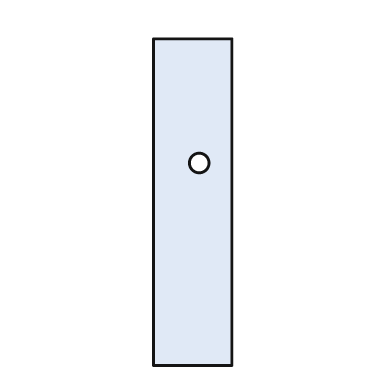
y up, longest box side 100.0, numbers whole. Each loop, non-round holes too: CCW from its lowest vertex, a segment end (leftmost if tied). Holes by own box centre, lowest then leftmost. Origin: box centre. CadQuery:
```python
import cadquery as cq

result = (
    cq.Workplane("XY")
    .moveTo(-12.0, -50.0)
    .lineTo(12.0, -50.0)
    .lineTo(12.0, 50.0)
    .lineTo(-12.0, 50.0)
    .close()
    .moveTo(2.0, 12.0)
    .circle(3.0)
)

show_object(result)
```